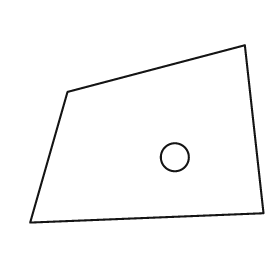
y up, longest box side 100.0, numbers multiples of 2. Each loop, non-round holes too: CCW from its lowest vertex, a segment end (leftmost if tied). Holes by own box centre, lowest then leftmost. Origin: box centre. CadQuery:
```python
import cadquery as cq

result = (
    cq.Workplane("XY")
    .moveTo(-50.0, -38.0)
    .lineTo(50.0, -34.0)
    .lineTo(42.0, 38.0)
    .lineTo(-34.0, 18.0)
    .close()
    .moveTo(12.0, -10.0)
    .circle(6.0)
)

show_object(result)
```